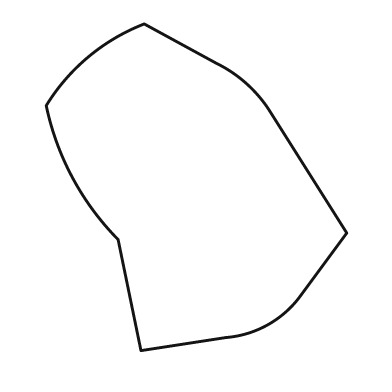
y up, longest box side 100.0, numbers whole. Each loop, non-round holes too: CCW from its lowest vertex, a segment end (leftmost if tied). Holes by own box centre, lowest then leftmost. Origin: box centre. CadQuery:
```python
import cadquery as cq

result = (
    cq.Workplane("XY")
    .moveTo(-17.0, -50.0)
    .lineTo(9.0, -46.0)
    .threePointArc((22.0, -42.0), (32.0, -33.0))
    .lineTo(46.0, -14.0)
    .lineTo(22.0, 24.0)
    .threePointArc((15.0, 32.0), (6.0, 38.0))
    .lineTo(-16.0, 50.0)
    .threePointArc((-33.0, 40.0), (-46.0, 25.0))
    .threePointArc((-38.0, 3.0), (-24.0, -16.0))
    .close()
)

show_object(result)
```